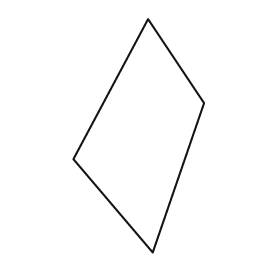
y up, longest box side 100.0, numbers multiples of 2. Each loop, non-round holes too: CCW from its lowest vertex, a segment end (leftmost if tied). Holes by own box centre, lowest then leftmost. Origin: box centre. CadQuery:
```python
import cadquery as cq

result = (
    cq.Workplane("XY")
    .moveTo(6.0, -50.0)
    .lineTo(28.0, 14.0)
    .lineTo(4.0, 50.0)
    .lineTo(-28.0, -10.0)
    .close()
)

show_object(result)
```